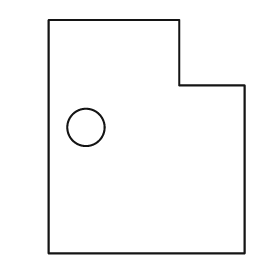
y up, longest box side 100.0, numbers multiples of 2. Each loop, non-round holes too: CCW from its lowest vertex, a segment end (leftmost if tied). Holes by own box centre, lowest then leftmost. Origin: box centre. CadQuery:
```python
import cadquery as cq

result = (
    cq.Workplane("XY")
    .moveTo(-42.0, -50.0)
    .lineTo(42.0, -50.0)
    .lineTo(42.0, 22.0)
    .lineTo(14.0, 22.0)
    .lineTo(14.0, 50.0)
    .lineTo(-42.0, 50.0)
    .close()
    .moveTo(-26.0, 4.0)
    .circle(8.0)
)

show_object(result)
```